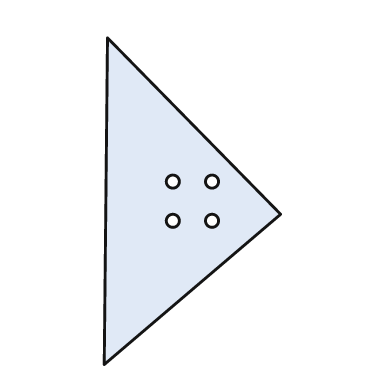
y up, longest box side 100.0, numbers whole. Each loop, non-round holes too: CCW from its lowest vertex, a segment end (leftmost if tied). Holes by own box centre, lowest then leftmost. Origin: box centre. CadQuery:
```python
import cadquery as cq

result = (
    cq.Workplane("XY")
    .moveTo(-27.0, -50.0)
    .lineTo(27.0, -4.0)
    .lineTo(-26.0, 50.0)
    .close()
    .moveTo(-6.0, -6.0)
    .circle(2.0)
    .moveTo(6.0, -6.0)
    .circle(2.0)
    .moveTo(-6.0, 6.0)
    .circle(2.0)
    .moveTo(6.0, 6.0)
    .circle(2.0)
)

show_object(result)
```